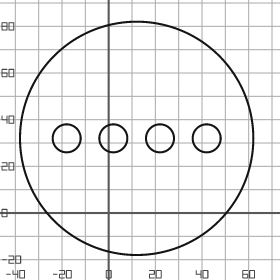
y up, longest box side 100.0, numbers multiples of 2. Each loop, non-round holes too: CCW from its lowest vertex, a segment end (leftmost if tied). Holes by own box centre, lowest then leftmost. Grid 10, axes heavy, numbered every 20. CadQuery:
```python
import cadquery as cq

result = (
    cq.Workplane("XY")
    .moveTo(12.0, 32.0)
    .circle(50.0)
    .moveTo(-18.0, 32.0)
    .circle(6.0)
    .moveTo(2.0, 32.0)
    .circle(6.0)
    .moveTo(22.0, 32.0)
    .circle(6.0)
    .moveTo(42.0, 32.0)
    .circle(6.0)
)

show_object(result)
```